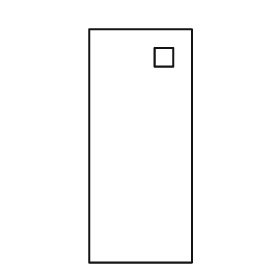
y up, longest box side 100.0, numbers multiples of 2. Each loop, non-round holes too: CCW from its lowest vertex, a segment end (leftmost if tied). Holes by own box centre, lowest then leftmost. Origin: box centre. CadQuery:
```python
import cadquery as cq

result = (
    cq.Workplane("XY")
    .moveTo(-22.0, -50.0)
    .lineTo(22.0, -50.0)
    .lineTo(22.0, 50.0)
    .lineTo(-22.0, 50.0)
    .close()
    .moveTo(6.0, 34.0)
    .lineTo(14.0, 34.0)
    .lineTo(14.0, 42.0)
    .lineTo(6.0, 42.0)
    .close()
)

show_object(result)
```